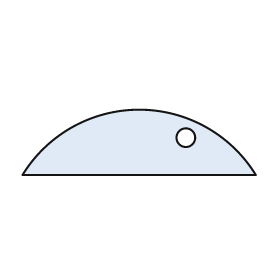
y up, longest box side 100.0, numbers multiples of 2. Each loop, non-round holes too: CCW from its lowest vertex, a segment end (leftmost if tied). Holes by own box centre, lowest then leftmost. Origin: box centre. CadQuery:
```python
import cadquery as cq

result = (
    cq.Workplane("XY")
    .moveTo(-50.0, -14.0)
    .lineTo(50.0, -14.0)
    .threePointArc((0.0, 14.0), (-50.0, -14.0))
    .close()
    .moveTo(20.0, 2.0)
    .circle(4.0)
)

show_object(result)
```